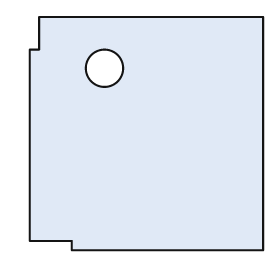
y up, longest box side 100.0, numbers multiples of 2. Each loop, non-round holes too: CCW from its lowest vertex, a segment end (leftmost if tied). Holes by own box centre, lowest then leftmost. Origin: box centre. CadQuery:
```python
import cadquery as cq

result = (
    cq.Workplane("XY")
    .moveTo(-32.0, -50.0)
    .lineTo(50.0, -50.0)
    .lineTo(50.0, 50.0)
    .lineTo(-46.0, 50.0)
    .lineTo(-46.0, 36.0)
    .lineTo(-50.0, 36.0)
    .lineTo(-50.0, -46.0)
    .lineTo(-32.0, -46.0)
    .close()
    .moveTo(-18.0, 28.0)
    .circle(8.0)
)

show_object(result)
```